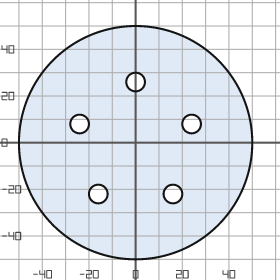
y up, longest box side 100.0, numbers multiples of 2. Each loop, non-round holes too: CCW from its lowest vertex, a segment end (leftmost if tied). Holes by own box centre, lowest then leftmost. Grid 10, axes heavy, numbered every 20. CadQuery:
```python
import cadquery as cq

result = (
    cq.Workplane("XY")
    .moveTo(0.0, 0.0)
    .circle(50.0)
    .moveTo(-16.0, -22.0)
    .circle(4.0)
    .moveTo(16.0, -22.0)
    .circle(4.0)
    .moveTo(-24.0, 8.0)
    .circle(4.0)
    .moveTo(24.0, 8.0)
    .circle(4.0)
    .moveTo(0.0, 26.0)
    .circle(4.0)
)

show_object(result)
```